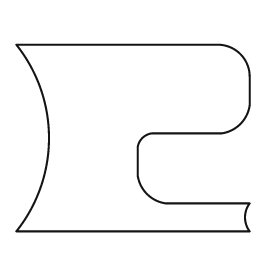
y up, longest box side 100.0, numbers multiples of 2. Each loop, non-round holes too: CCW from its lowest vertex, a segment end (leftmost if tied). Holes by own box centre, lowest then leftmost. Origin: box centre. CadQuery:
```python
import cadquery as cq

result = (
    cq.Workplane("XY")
    .moveTo(-50.0, -40.0)
    .lineTo(50.0, -40.0)
    .threePointArc((48.0, -34.0), (50.0, -28.0))
    .lineTo(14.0, -28.0)
    .threePointArc((6.0, -24.0), (2.0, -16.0))
    .lineTo(2.0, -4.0)
    .threePointArc((4.0, 0.0), (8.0, 2.0))
    .lineTo(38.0, 2.0)
    .threePointArc((46.0, 6.0), (50.0, 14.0))
    .lineTo(50.0, 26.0)
    .threePointArc((46.0, 36.0), (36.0, 40.0))
    .lineTo(-50.0, 40.0)
    .threePointArc((-36.0, 0.0), (-50.0, -40.0))
    .close()
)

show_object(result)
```